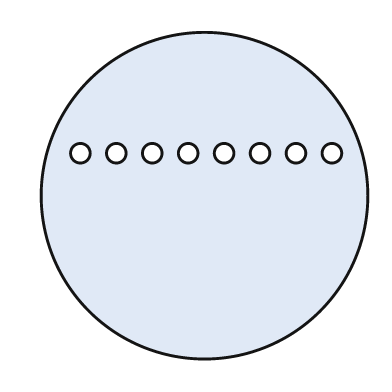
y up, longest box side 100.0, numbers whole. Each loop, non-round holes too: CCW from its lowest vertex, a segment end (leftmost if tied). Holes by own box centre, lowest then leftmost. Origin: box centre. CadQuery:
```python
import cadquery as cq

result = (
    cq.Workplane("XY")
    .moveTo(0.0, 0.0)
    .circle(50.0)
    .moveTo(-38.0, 13.0)
    .circle(3.0)
    .moveTo(-27.0, 13.0)
    .circle(3.0)
    .moveTo(-16.0, 13.0)
    .circle(3.0)
    .moveTo(-5.0, 13.0)
    .circle(3.0)
    .moveTo(6.0, 13.0)
    .circle(3.0)
    .moveTo(17.0, 13.0)
    .circle(3.0)
    .moveTo(28.0, 13.0)
    .circle(3.0)
    .moveTo(39.0, 13.0)
    .circle(3.0)
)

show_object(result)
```